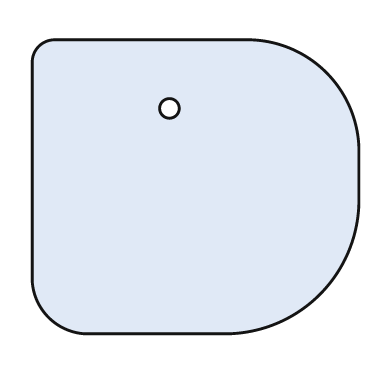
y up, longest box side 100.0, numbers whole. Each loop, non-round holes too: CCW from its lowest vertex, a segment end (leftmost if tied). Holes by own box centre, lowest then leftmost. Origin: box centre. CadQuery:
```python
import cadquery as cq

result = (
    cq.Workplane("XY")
    .moveTo(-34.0, -45.0)
    .lineTo(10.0, -45.0)
    .threePointArc((38.0, -33.0), (50.0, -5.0))
    .lineTo(50.0, 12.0)
    .threePointArc((40.0, 35.0), (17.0, 45.0))
    .lineTo(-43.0, 45.0)
    .threePointArc((-48.0, 43.0), (-50.0, 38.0))
    .lineTo(-50.0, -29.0)
    .threePointArc((-45.0, -40.0), (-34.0, -45.0))
    .close()
    .moveTo(-8.0, 24.0)
    .circle(3.0)
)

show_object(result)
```